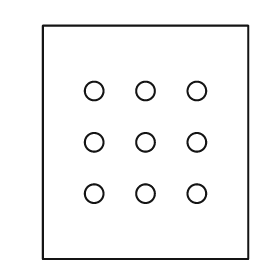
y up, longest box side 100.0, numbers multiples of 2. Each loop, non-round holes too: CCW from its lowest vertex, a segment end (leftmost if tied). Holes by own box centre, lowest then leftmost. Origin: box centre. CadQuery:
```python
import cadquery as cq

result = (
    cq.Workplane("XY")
    .moveTo(-44.0, -50.0)
    .lineTo(44.0, -50.0)
    .lineTo(44.0, 50.0)
    .lineTo(-44.0, 50.0)
    .close()
    .moveTo(-22.0, -22.0)
    .circle(4.0)
    .moveTo(0.0, -22.0)
    .circle(4.0)
    .moveTo(22.0, -22.0)
    .circle(4.0)
    .moveTo(-22.0, 0.0)
    .circle(4.0)
    .moveTo(0.0, 0.0)
    .circle(4.0)
    .moveTo(22.0, 0.0)
    .circle(4.0)
    .moveTo(-22.0, 22.0)
    .circle(4.0)
    .moveTo(0.0, 22.0)
    .circle(4.0)
    .moveTo(22.0, 22.0)
    .circle(4.0)
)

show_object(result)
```